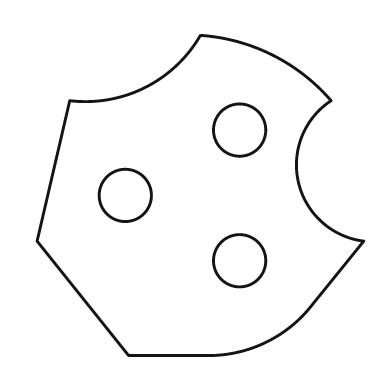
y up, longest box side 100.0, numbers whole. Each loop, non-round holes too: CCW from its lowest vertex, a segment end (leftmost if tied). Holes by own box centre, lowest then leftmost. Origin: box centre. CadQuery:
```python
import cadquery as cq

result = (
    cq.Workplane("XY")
    .moveTo(-22.0, -49.0)
    .lineTo(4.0, -49.0)
    .threePointArc((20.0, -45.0), (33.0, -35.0))
    .lineTo(50.0, -14.0)
    .threePointArc((30.0, 4.0), (40.0, 29.0))
    .threePointArc((22.0, 43.0), (0.0, 49.0))
    .threePointArc((-17.0, 33.0), (-40.0, 29.0))
    .lineTo(-50.0, -14.0)
    .close()
    .moveTo(12.0, -20.0)
    .circle(8.0)
    .moveTo(-23.0, 0.0)
    .circle(8.0)
    .moveTo(12.0, 20.0)
    .circle(8.0)
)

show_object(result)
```